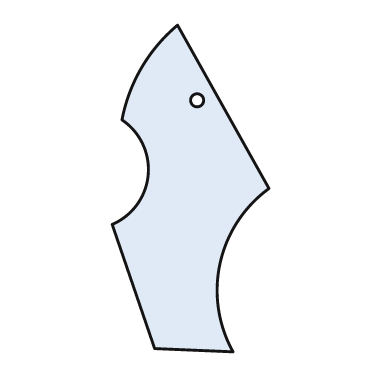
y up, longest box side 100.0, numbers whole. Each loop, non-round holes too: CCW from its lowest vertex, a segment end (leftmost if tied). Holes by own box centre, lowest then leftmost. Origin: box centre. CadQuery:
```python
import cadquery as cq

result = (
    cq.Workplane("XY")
    .moveTo(13.0, -50.0)
    .threePointArc((9.0, -23.0), (24.0, 0.0))
    .lineTo(-4.0, 50.0)
    .threePointArc((-15.0, 37.0), (-21.0, 21.0))
    .threePointArc((-13.0, 4.0), (-24.0, -11.0))
    .lineTo(-11.0, -49.0)
    .close()
    .moveTo(2.0, 27.0)
    .circle(2.0)
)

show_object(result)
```